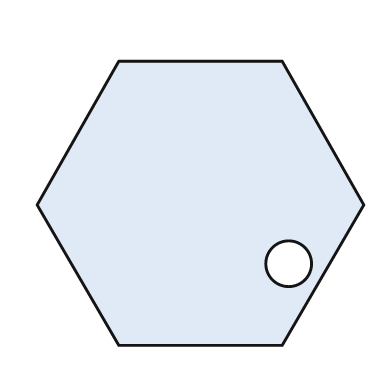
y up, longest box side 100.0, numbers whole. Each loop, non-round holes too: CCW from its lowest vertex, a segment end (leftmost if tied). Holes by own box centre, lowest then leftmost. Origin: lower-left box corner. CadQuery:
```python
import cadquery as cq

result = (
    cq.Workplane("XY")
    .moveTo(25.0, 0.0)
    .lineTo(75.0, 0.0)
    .lineTo(100.0, 43.0)
    .lineTo(75.0, 87.0)
    .lineTo(25.0, 87.0)
    .lineTo(0.0, 43.0)
    .close()
    .moveTo(77.0, 25.0)
    .circle(7.0)
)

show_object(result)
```